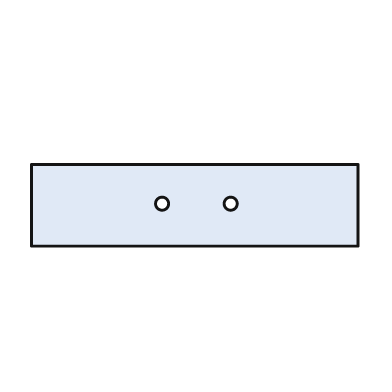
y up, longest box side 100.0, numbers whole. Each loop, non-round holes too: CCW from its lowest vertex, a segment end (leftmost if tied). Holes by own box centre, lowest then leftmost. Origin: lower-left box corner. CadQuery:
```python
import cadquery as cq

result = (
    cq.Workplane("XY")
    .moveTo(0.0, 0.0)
    .lineTo(100.0, 0.0)
    .lineTo(100.0, 25.0)
    .lineTo(0.0, 25.0)
    .close()
    .moveTo(40.0, 13.0)
    .circle(2.0)
    .moveTo(61.0, 13.0)
    .circle(2.0)
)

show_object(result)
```